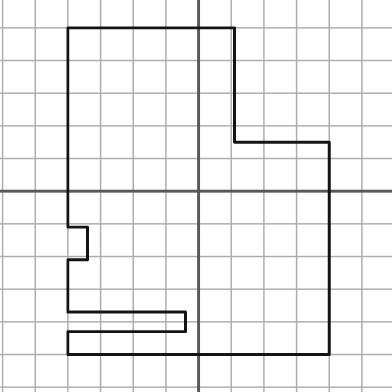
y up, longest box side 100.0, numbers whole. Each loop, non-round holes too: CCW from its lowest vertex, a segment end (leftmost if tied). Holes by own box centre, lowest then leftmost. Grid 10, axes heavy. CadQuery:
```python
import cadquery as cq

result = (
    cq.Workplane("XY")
    .moveTo(-40.0, -50.0)
    .lineTo(40.0, -50.0)
    .lineTo(40.0, 15.0)
    .lineTo(11.0, 15.0)
    .lineTo(11.0, 50.0)
    .lineTo(-40.0, 50.0)
    .lineTo(-40.0, -11.0)
    .lineTo(-34.0, -11.0)
    .lineTo(-34.0, -21.0)
    .lineTo(-40.0, -21.0)
    .lineTo(-40.0, -37.0)
    .lineTo(-4.0, -37.0)
    .lineTo(-4.0, -43.0)
    .lineTo(-40.0, -43.0)
    .close()
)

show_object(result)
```